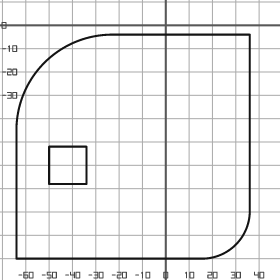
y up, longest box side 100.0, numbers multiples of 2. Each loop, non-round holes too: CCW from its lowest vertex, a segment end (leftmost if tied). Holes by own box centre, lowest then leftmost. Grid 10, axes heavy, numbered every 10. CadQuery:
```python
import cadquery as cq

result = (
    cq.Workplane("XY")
    .moveTo(-64.0, -100.0)
    .lineTo(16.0, -100.0)
    .threePointArc((30.0, -94.0), (36.0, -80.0))
    .lineTo(36.0, -4.0)
    .lineTo(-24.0, -4.0)
    .threePointArc((-52.0, -16.0), (-64.0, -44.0))
    .close()
    .moveTo(-50.0, -68.0)
    .lineTo(-34.0, -68.0)
    .lineTo(-34.0, -52.0)
    .lineTo(-50.0, -52.0)
    .close()
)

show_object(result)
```